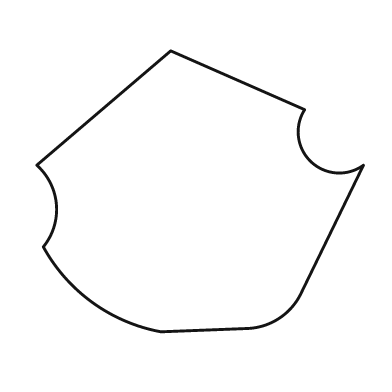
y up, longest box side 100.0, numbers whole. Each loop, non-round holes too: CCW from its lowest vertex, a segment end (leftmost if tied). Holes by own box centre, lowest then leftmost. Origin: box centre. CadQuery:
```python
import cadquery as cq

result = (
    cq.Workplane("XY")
    .moveTo(-12.0, -43.0)
    .lineTo(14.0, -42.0)
    .threePointArc((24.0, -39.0), (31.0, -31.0))
    .lineTo(50.0, 8.0)
    .threePointArc((34.0, 9.0), (32.0, 25.0))
    .lineTo(-9.0, 43.0)
    .lineTo(-50.0, 8.0)
    .threePointArc((-44.0, -4.0), (-48.0, -17.0))
    .threePointArc((-33.0, -34.0), (-12.0, -43.0))
    .close()
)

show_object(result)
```